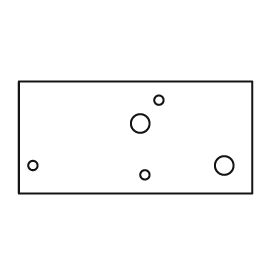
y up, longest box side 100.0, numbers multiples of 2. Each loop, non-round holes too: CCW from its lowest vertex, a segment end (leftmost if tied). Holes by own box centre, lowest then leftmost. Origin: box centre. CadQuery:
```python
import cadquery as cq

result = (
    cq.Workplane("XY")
    .moveTo(-50.0, -24.0)
    .lineTo(50.0, -24.0)
    .lineTo(50.0, 24.0)
    .lineTo(-50.0, 24.0)
    .close()
    .moveTo(4.0, -16.0)
    .circle(2.0)
    .moveTo(-44.0, -12.0)
    .circle(2.0)
    .moveTo(38.0, -12.0)
    .circle(4.0)
    .moveTo(2.0, 6.0)
    .circle(4.0)
    .moveTo(10.0, 16.0)
    .circle(2.0)
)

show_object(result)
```